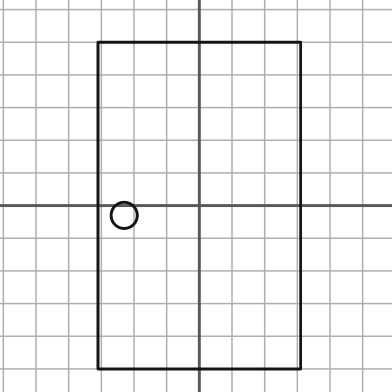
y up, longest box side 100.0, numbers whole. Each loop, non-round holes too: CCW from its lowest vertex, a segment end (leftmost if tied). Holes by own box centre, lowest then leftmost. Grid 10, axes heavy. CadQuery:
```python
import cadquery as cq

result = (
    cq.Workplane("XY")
    .moveTo(-31.0, -50.0)
    .lineTo(31.0, -50.0)
    .lineTo(31.0, 50.0)
    .lineTo(-31.0, 50.0)
    .close()
    .moveTo(-23.0, -3.0)
    .circle(4.0)
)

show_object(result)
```